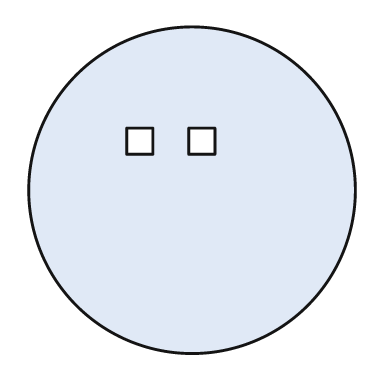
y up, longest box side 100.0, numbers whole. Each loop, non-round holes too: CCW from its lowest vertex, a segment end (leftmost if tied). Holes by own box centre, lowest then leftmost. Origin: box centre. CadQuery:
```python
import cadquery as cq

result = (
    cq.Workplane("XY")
    .moveTo(0.0, 0.0)
    .circle(50.0)
    .moveTo(-20.0, 11.0)
    .lineTo(-12.0, 11.0)
    .lineTo(-12.0, 19.0)
    .lineTo(-20.0, 19.0)
    .close()
    .moveTo(-1.0, 11.0)
    .lineTo(7.0, 11.0)
    .lineTo(7.0, 19.0)
    .lineTo(-1.0, 19.0)
    .close()
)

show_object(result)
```